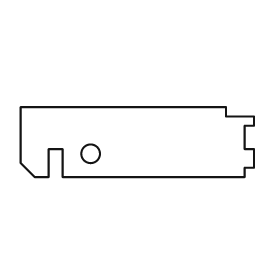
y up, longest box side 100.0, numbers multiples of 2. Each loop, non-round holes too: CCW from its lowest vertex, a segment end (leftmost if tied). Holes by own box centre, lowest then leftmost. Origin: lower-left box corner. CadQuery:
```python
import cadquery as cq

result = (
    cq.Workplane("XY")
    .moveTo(6.0, 0.0)
    .lineTo(12.0, 0.0)
    .lineTo(12.0, 12.0)
    .lineTo(18.0, 12.0)
    .lineTo(18.0, 0.0)
    .lineTo(96.0, 0.0)
    .lineTo(96.0, 4.0)
    .lineTo(100.0, 4.0)
    .lineTo(100.0, 12.0)
    .lineTo(96.0, 12.0)
    .lineTo(96.0, 22.0)
    .lineTo(100.0, 22.0)
    .lineTo(100.0, 26.0)
    .lineTo(88.0, 26.0)
    .lineTo(88.0, 30.0)
    .lineTo(0.0, 30.0)
    .lineTo(0.0, 6.0)
    .close()
    .moveTo(30.0, 10.0)
    .circle(4.0)
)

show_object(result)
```